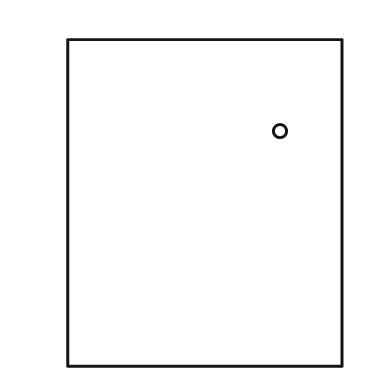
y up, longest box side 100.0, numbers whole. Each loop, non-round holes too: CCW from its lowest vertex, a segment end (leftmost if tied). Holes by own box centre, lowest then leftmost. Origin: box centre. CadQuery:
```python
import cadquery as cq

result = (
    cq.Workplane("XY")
    .moveTo(-42.0, -50.0)
    .lineTo(42.0, -50.0)
    .lineTo(42.0, 50.0)
    .lineTo(-42.0, 50.0)
    .close()
    .moveTo(23.0, 22.0)
    .circle(2.0)
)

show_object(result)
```